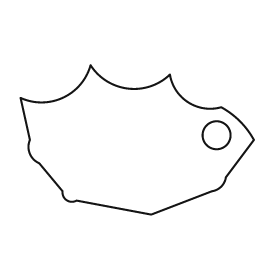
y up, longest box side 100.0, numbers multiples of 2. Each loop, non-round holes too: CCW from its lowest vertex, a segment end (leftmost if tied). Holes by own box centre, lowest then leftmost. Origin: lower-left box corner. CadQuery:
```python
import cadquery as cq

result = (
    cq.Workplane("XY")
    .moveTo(56.0, 0.0)
    .lineTo(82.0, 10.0)
    .threePointArc((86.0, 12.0), (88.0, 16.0))
    .lineTo(100.0, 32.0)
    .threePointArc((94.0, 40.0), (86.0, 46.0))
    .threePointArc((72.0, 48.0), (64.0, 60.0))
    .threePointArc((46.0, 54.0), (30.0, 64.0))
    .threePointArc((18.0, 50.0), (0.0, 50.0))
    .lineTo(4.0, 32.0)
    .threePointArc((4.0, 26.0), (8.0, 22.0))
    .lineTo(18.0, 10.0)
    .threePointArc((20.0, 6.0), (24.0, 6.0))
    .close()
    .moveTo(84.0, 34.0)
    .circle(6.0)
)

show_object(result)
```